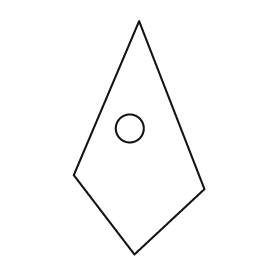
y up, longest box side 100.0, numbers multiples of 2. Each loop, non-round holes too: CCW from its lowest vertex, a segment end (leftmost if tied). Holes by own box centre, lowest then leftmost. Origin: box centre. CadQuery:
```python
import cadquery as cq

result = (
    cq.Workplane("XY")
    .moveTo(-2.0, -50.0)
    .lineTo(28.0, -22.0)
    .lineTo(0.0, 50.0)
    .lineTo(-28.0, -16.0)
    .close()
    .moveTo(-4.0, 4.0)
    .circle(6.0)
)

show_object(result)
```